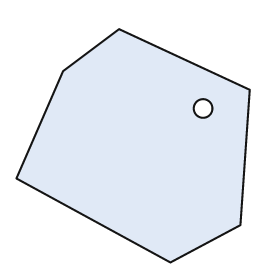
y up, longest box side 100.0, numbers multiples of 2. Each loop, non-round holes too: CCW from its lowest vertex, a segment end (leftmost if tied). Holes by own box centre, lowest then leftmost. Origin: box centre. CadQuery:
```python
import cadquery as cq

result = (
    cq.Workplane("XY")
    .moveTo(16.0, -50.0)
    .lineTo(46.0, -34.0)
    .lineTo(50.0, 24.0)
    .lineTo(-6.0, 50.0)
    .lineTo(-30.0, 32.0)
    .lineTo(-50.0, -14.0)
    .close()
    .moveTo(30.0, 16.0)
    .circle(4.0)
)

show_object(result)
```